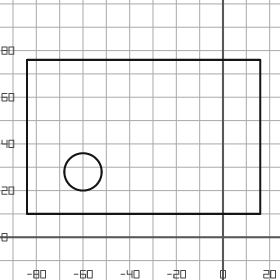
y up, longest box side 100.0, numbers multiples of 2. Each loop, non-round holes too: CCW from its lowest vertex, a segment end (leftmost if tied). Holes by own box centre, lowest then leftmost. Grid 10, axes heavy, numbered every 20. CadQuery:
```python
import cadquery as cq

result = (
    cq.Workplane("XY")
    .moveTo(-84.0, 10.0)
    .lineTo(16.0, 10.0)
    .lineTo(16.0, 76.0)
    .lineTo(-84.0, 76.0)
    .close()
    .moveTo(-60.0, 28.0)
    .circle(8.0)
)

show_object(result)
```